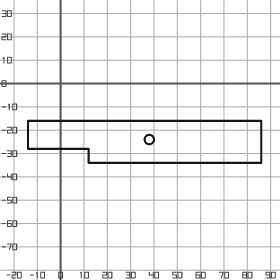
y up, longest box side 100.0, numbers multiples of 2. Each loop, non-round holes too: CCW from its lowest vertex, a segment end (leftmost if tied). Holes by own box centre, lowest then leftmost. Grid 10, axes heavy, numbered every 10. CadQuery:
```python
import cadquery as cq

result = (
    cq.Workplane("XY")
    .moveTo(12.0, -34.0)
    .lineTo(86.0, -34.0)
    .lineTo(86.0, -16.0)
    .lineTo(-14.0, -16.0)
    .lineTo(-14.0, -28.0)
    .lineTo(12.0, -28.0)
    .close()
    .moveTo(38.0, -24.0)
    .circle(2.0)
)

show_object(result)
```